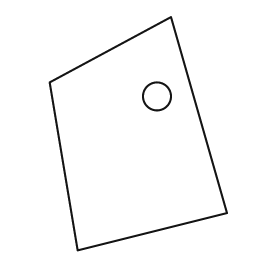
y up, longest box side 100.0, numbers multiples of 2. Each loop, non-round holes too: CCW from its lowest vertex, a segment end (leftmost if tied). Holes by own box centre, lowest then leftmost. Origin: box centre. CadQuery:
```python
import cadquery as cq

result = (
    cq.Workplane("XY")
    .moveTo(-26.0, -50.0)
    .lineTo(38.0, -34.0)
    .lineTo(14.0, 50.0)
    .lineTo(-38.0, 22.0)
    .close()
    .moveTo(8.0, 16.0)
    .circle(6.0)
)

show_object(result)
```